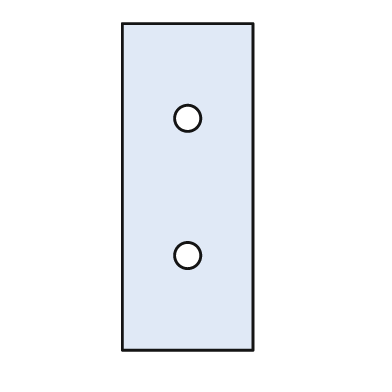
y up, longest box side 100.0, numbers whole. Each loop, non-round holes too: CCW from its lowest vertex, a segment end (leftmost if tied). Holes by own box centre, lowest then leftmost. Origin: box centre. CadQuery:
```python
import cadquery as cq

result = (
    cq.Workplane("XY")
    .moveTo(-20.0, -50.0)
    .lineTo(20.0, -50.0)
    .lineTo(20.0, 50.0)
    .lineTo(-20.0, 50.0)
    .close()
    .moveTo(0.0, -21.0)
    .circle(4.0)
    .moveTo(0.0, 21.0)
    .circle(4.0)
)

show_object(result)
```